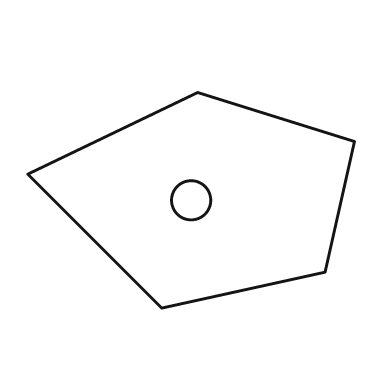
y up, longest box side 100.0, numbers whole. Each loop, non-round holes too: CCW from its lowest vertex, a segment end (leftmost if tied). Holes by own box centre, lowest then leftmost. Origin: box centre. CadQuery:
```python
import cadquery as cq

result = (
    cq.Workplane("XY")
    .moveTo(-9.0, -33.0)
    .lineTo(41.0, -22.0)
    .lineTo(50.0, 18.0)
    .lineTo(2.0, 33.0)
    .lineTo(-50.0, 8.0)
    .close()
    .moveTo(0.0, 0.0)
    .circle(6.0)
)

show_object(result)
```